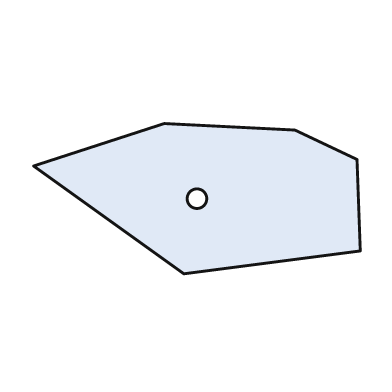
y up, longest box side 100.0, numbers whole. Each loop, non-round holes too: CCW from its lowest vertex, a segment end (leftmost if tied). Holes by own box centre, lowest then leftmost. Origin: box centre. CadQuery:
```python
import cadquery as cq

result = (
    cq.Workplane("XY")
    .moveTo(-4.0, -23.0)
    .lineTo(50.0, -16.0)
    .lineTo(49.0, 12.0)
    .lineTo(30.0, 21.0)
    .lineTo(-10.0, 23.0)
    .lineTo(-50.0, 10.0)
    .close()
    .moveTo(0.0, 0.0)
    .circle(3.0)
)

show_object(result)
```